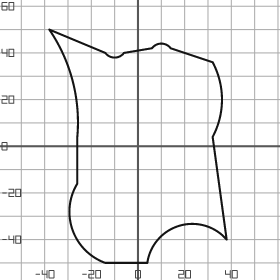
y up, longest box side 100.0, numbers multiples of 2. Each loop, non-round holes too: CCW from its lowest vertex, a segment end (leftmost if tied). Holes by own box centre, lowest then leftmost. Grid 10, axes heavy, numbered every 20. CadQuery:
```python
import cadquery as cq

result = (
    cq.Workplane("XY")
    .moveTo(-14.0, -50.0)
    .lineTo(4.0, -50.0)
    .threePointArc((18.0, -34.0), (38.0, -40.0))
    .lineTo(32.0, 4.0)
    .threePointArc((36.0, 20.0), (32.0, 36.0))
    .lineTo(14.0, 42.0)
    .threePointArc((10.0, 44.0), (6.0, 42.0))
    .lineTo(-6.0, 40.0)
    .threePointArc((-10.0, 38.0), (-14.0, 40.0))
    .lineTo(-38.0, 50.0)
    .threePointArc((-28.0, 28.0), (-26.0, 4.0))
    .lineTo(-26.0, -16.0)
    .threePointArc((-28.0, -36.0), (-14.0, -50.0))
    .close()
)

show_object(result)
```